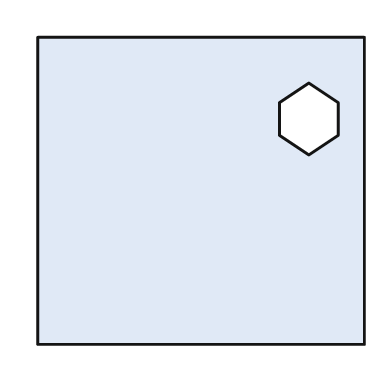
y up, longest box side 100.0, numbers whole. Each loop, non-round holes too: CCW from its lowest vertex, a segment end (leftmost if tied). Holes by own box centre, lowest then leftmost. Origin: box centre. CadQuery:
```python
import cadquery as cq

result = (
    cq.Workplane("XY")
    .moveTo(-50.0, -47.0)
    .lineTo(50.0, -47.0)
    .lineTo(50.0, 47.0)
    .lineTo(-50.0, 47.0)
    .close()
    .moveTo(33.0, 11.0)
    .lineTo(42.0, 17.0)
    .lineTo(42.0, 27.0)
    .lineTo(33.0, 33.0)
    .lineTo(24.0, 27.0)
    .lineTo(24.0, 17.0)
    .close()
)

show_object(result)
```